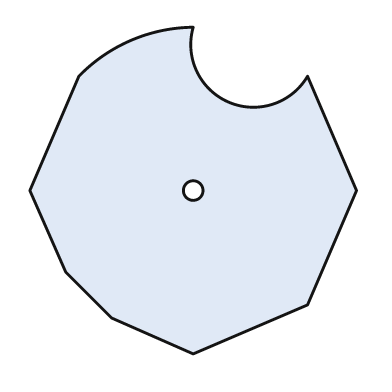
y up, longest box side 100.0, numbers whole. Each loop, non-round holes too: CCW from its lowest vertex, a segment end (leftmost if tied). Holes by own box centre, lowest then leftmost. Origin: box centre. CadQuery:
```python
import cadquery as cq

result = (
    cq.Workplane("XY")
    .moveTo(0.0, -50.0)
    .lineTo(35.0, -35.0)
    .lineTo(50.0, 0.0)
    .lineTo(35.0, 35.0)
    .threePointArc((11.0, 27.0), (0.0, 50.0))
    .threePointArc((-19.0, 46.0), (-35.0, 35.0))
    .lineTo(-50.0, 0.0)
    .lineTo(-39.0, -25.0)
    .lineTo(-25.0, -39.0)
    .close()
    .moveTo(0.0, 0.0)
    .circle(3.0)
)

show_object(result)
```